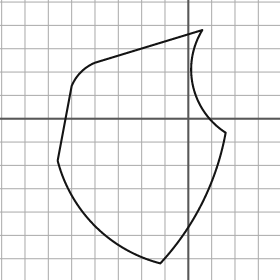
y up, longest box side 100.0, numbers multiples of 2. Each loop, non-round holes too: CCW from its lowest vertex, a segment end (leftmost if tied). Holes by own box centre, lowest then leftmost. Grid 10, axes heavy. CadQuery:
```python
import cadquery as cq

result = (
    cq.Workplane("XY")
    .moveTo(-12.0, -62.0)
    .threePointArc((6.0, -36.0), (16.0, -6.0))
    .threePointArc((2.0, 14.0), (6.0, 38.0))
    .lineTo(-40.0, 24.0)
    .threePointArc((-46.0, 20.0), (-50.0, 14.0))
    .lineTo(-56.0, -18.0)
    .threePointArc((-40.0, -46.0), (-12.0, -62.0))
    .close()
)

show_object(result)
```